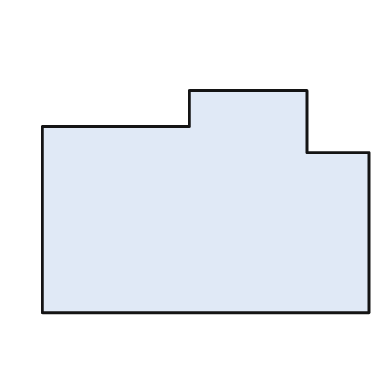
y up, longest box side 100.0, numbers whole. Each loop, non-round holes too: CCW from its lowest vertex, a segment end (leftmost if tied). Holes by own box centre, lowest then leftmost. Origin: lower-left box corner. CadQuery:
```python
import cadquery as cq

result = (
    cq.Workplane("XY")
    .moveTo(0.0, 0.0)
    .lineTo(100.0, 0.0)
    .lineTo(100.0, 49.0)
    .lineTo(81.0, 49.0)
    .lineTo(81.0, 68.0)
    .lineTo(45.0, 68.0)
    .lineTo(45.0, 57.0)
    .lineTo(0.0, 57.0)
    .close()
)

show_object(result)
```